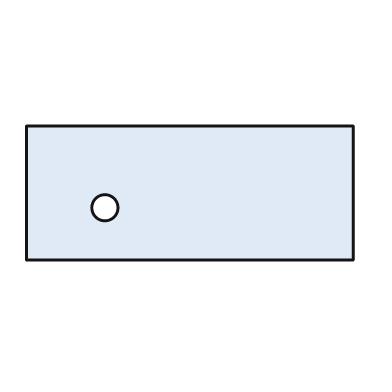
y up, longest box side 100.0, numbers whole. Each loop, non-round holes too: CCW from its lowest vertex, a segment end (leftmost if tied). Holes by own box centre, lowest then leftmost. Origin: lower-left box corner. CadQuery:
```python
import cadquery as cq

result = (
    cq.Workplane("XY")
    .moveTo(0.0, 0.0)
    .lineTo(100.0, 0.0)
    .lineTo(100.0, 41.0)
    .lineTo(0.0, 41.0)
    .close()
    .moveTo(24.0, 16.0)
    .circle(4.0)
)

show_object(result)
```